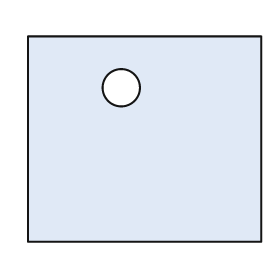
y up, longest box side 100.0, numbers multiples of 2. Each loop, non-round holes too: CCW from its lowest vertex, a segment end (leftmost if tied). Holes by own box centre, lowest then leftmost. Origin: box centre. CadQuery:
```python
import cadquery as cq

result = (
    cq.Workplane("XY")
    .moveTo(-50.0, -44.0)
    .lineTo(50.0, -44.0)
    .lineTo(50.0, 44.0)
    .lineTo(-50.0, 44.0)
    .close()
    .moveTo(-10.0, 22.0)
    .circle(8.0)
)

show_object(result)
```